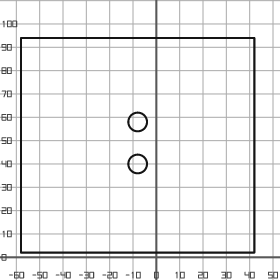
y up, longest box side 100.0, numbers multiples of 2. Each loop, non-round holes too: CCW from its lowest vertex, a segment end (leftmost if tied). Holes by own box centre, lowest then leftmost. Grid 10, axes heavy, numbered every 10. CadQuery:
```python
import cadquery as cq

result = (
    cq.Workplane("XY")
    .moveTo(-58.0, 2.0)
    .lineTo(42.0, 2.0)
    .lineTo(42.0, 94.0)
    .lineTo(-58.0, 94.0)
    .close()
    .moveTo(-8.0, 40.0)
    .circle(4.0)
    .moveTo(-8.0, 58.0)
    .circle(4.0)
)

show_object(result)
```